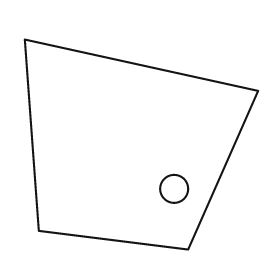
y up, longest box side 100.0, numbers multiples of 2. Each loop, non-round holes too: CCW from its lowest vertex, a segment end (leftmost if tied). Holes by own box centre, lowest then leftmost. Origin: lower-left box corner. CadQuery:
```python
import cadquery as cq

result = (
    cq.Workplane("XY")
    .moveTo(70.0, 0.0)
    .lineTo(100.0, 68.0)
    .lineTo(0.0, 90.0)
    .lineTo(6.0, 8.0)
    .close()
    .moveTo(64.0, 26.0)
    .circle(6.0)
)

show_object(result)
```